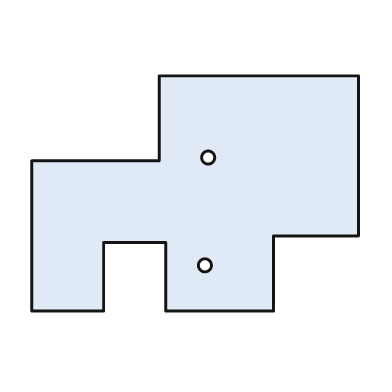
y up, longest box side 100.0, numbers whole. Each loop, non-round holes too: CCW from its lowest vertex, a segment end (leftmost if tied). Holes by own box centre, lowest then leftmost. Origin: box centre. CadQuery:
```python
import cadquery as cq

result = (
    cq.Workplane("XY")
    .moveTo(-50.0, -36.0)
    .lineTo(-28.0, -36.0)
    .lineTo(-28.0, -15.0)
    .lineTo(-9.0, -15.0)
    .lineTo(-9.0, -36.0)
    .lineTo(24.0, -36.0)
    .lineTo(24.0, -13.0)
    .lineTo(50.0, -13.0)
    .lineTo(50.0, 36.0)
    .lineTo(-11.0, 36.0)
    .lineTo(-11.0, 10.0)
    .lineTo(-50.0, 10.0)
    .close()
    .moveTo(3.0, -22.0)
    .circle(2.0)
    .moveTo(4.0, 11.0)
    .circle(2.0)
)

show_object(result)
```